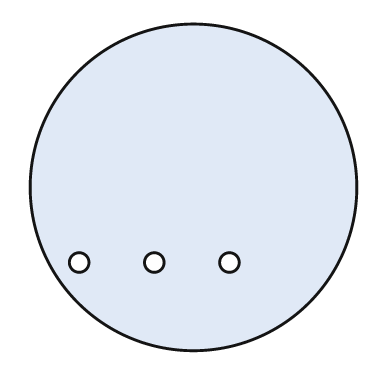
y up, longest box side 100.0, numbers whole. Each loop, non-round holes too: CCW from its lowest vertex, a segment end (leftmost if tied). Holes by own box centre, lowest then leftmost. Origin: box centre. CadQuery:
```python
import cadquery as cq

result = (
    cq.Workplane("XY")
    .moveTo(0.0, 0.0)
    .circle(50.0)
    .moveTo(-35.0, -23.0)
    .circle(3.0)
    .moveTo(-12.0, -23.0)
    .circle(3.0)
    .moveTo(11.0, -23.0)
    .circle(3.0)
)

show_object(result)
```